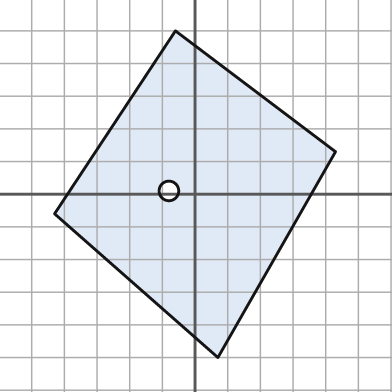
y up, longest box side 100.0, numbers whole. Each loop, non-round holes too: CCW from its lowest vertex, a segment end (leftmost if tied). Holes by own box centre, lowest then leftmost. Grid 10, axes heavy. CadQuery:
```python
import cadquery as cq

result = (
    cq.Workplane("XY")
    .moveTo(7.0, -50.0)
    .lineTo(43.0, 13.0)
    .lineTo(-6.0, 50.0)
    .lineTo(-43.0, -6.0)
    .close()
    .moveTo(-8.0, 1.0)
    .circle(3.0)
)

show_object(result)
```